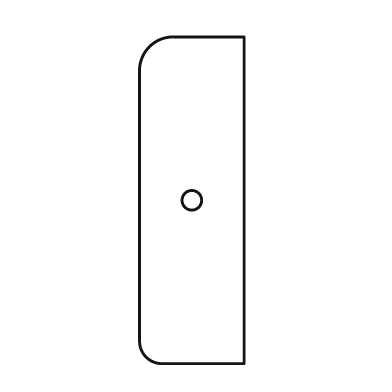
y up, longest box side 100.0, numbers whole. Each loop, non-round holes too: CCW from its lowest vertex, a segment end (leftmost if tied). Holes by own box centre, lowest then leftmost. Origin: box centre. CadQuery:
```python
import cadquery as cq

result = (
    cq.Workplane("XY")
    .moveTo(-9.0, -50.0)
    .lineTo(16.0, -50.0)
    .lineTo(16.0, 50.0)
    .lineTo(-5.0, 50.0)
    .threePointArc((-13.0, 47.0), (-16.0, 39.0))
    .lineTo(-16.0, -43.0)
    .threePointArc((-14.0, -48.0), (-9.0, -50.0))
    .close()
    .moveTo(0.0, 0.0)
    .circle(3.0)
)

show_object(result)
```